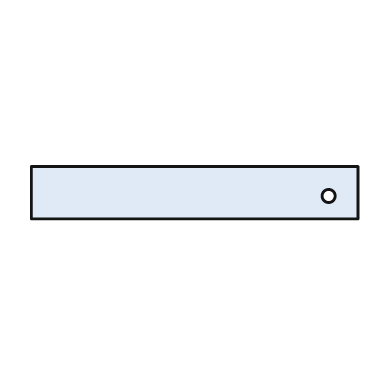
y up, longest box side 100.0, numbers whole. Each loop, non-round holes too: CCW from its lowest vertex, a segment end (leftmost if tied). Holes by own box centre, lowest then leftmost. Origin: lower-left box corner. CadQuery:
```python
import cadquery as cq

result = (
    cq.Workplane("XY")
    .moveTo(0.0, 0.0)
    .lineTo(100.0, 0.0)
    .lineTo(100.0, 16.0)
    .lineTo(0.0, 16.0)
    .close()
    .moveTo(91.0, 7.0)
    .circle(2.0)
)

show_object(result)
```